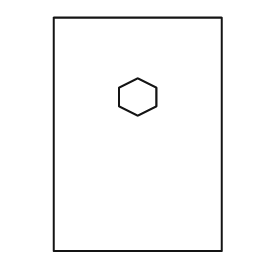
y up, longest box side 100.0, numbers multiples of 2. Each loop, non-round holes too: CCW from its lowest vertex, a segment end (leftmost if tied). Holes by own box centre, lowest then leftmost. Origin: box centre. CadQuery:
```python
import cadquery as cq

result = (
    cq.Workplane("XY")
    .moveTo(-36.0, -50.0)
    .lineTo(36.0, -50.0)
    .lineTo(36.0, 50.0)
    .lineTo(-36.0, 50.0)
    .close()
    .moveTo(0.0, 8.0)
    .lineTo(8.0, 12.0)
    .lineTo(8.0, 20.0)
    .lineTo(0.0, 24.0)
    .lineTo(-8.0, 20.0)
    .lineTo(-8.0, 12.0)
    .close()
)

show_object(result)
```